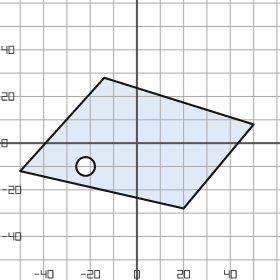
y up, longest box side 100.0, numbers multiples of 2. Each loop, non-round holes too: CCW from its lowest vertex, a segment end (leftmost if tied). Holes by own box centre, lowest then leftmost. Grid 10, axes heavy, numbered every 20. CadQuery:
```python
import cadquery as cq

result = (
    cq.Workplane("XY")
    .moveTo(20.0, -28.0)
    .lineTo(50.0, 8.0)
    .lineTo(-14.0, 28.0)
    .lineTo(-50.0, -12.0)
    .close()
    .moveTo(-22.0, -10.0)
    .circle(4.0)
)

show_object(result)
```